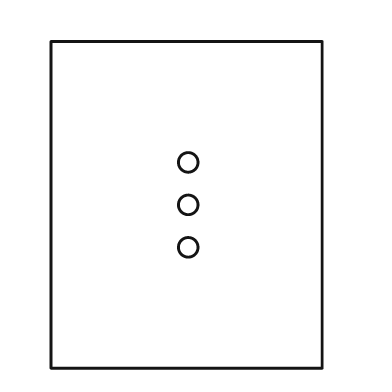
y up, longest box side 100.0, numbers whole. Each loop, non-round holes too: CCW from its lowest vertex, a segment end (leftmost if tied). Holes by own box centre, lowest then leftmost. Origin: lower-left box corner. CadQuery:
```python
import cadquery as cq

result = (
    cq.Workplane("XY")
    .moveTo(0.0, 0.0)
    .lineTo(83.0, 0.0)
    .lineTo(83.0, 100.0)
    .lineTo(0.0, 100.0)
    .close()
    .moveTo(42.0, 37.0)
    .circle(3.0)
    .moveTo(42.0, 50.0)
    .circle(3.0)
    .moveTo(42.0, 63.0)
    .circle(3.0)
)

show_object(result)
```